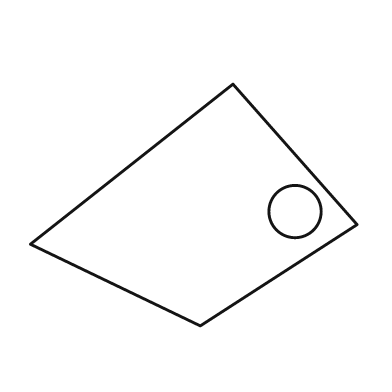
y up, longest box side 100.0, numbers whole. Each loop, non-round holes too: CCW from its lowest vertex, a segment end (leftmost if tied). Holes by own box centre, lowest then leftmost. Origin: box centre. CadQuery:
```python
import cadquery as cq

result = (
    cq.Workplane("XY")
    .moveTo(2.0, -37.0)
    .lineTo(50.0, -6.0)
    .lineTo(12.0, 37.0)
    .lineTo(-50.0, -12.0)
    .close()
    .moveTo(31.0, -2.0)
    .circle(8.0)
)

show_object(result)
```